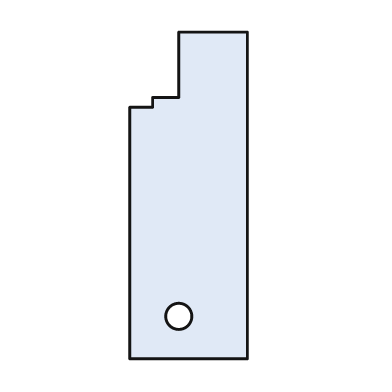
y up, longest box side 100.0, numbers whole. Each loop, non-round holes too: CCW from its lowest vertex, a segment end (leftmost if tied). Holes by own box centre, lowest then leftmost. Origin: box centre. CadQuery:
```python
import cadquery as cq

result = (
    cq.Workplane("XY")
    .moveTo(-18.0, -50.0)
    .lineTo(18.0, -50.0)
    .lineTo(18.0, 50.0)
    .lineTo(-3.0, 50.0)
    .lineTo(-3.0, 30.0)
    .lineTo(-11.0, 30.0)
    .lineTo(-11.0, 27.0)
    .lineTo(-18.0, 27.0)
    .close()
    .moveTo(-3.0, -37.0)
    .circle(4.0)
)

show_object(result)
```